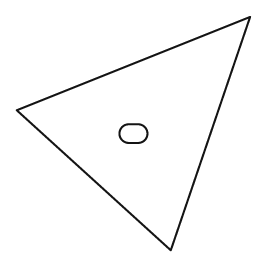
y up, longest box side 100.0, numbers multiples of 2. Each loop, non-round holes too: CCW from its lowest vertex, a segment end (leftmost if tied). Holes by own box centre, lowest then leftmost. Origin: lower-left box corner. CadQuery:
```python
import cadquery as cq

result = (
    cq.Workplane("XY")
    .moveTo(66.0, 0.0)
    .lineTo(100.0, 100.0)
    .lineTo(0.0, 60.0)
    .close()
    .moveTo(48.0, 46.0)
    .lineTo(52.0, 46.0)
    .threePointArc((56.0, 50.0), (52.0, 54.0))
    .lineTo(48.0, 54.0)
    .threePointArc((44.0, 50.0), (48.0, 46.0))
    .close()
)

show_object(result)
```